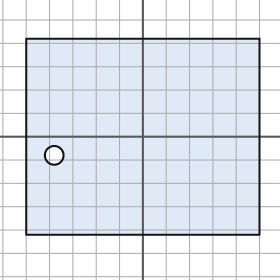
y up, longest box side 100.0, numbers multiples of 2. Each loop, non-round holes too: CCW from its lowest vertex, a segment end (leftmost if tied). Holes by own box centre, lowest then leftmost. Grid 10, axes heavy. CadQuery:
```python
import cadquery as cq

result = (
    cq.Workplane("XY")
    .moveTo(-50.0, -42.0)
    .lineTo(50.0, -42.0)
    .lineTo(50.0, 42.0)
    .lineTo(-50.0, 42.0)
    .close()
    .moveTo(-38.0, -8.0)
    .circle(4.0)
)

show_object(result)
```